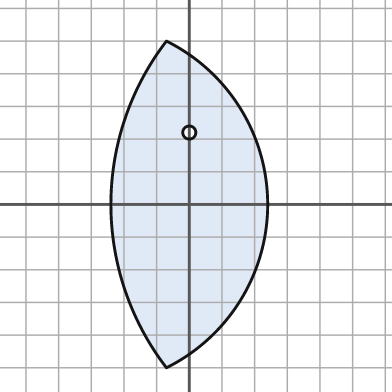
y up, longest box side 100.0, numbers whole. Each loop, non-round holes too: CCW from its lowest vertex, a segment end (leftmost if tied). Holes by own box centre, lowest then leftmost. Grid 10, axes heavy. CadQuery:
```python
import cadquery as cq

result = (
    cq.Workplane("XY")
    .moveTo(-7.0, -50.0)
    .threePointArc((24.0, 0.0), (-7.0, 50.0))
    .threePointArc((-24.0, 0.0), (-7.0, -50.0))
    .close()
    .moveTo(0.0, 22.0)
    .circle(2.0)
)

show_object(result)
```